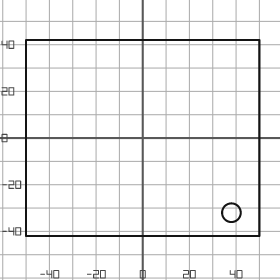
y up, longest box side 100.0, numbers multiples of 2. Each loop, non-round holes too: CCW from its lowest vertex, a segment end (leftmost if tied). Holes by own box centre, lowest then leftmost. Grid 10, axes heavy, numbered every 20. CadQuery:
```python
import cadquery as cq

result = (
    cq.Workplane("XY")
    .moveTo(-50.0, -42.0)
    .lineTo(50.0, -42.0)
    .lineTo(50.0, 42.0)
    .lineTo(-50.0, 42.0)
    .close()
    .moveTo(38.0, -32.0)
    .circle(4.0)
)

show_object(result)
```